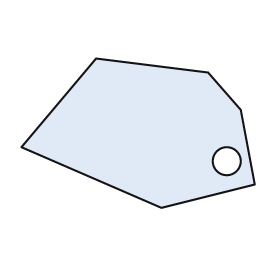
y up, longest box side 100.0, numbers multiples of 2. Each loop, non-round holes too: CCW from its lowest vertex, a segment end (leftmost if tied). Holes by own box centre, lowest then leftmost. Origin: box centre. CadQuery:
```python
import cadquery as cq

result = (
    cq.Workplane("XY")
    .moveTo(10.0, -32.0)
    .lineTo(50.0, -22.0)
    .lineTo(44.0, 10.0)
    .lineTo(30.0, 26.0)
    .lineTo(-18.0, 32.0)
    .lineTo(-50.0, -6.0)
    .close()
    .moveTo(38.0, -12.0)
    .circle(6.0)
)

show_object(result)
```